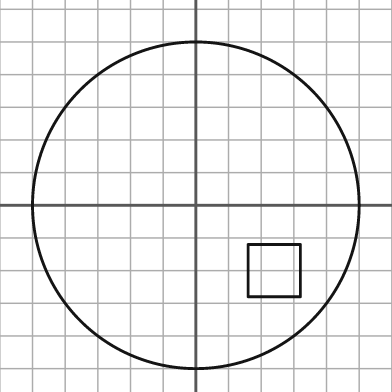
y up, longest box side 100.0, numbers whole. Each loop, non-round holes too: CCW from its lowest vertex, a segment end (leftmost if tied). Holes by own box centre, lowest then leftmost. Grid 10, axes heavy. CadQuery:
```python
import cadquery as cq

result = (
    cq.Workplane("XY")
    .moveTo(0.0, 0.0)
    .circle(50.0)
    .moveTo(16.0, -28.0)
    .lineTo(32.0, -28.0)
    .lineTo(32.0, -12.0)
    .lineTo(16.0, -12.0)
    .close()
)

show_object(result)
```